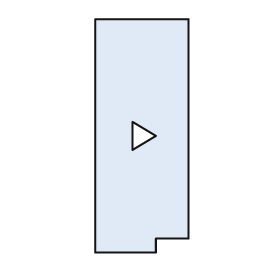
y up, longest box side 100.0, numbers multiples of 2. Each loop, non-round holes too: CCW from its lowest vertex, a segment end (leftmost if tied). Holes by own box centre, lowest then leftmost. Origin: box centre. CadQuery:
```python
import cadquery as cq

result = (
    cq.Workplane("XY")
    .moveTo(-20.0, -50.0)
    .lineTo(6.0, -50.0)
    .lineTo(6.0, -44.0)
    .lineTo(20.0, -44.0)
    .lineTo(20.0, 50.0)
    .lineTo(-20.0, 50.0)
    .close()
    .moveTo(-4.0, -6.0)
    .lineTo(6.0, 0.0)
    .lineTo(-4.0, 6.0)
    .close()
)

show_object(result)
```